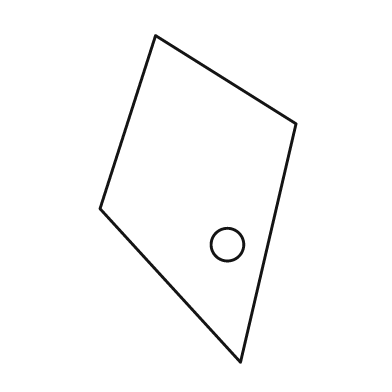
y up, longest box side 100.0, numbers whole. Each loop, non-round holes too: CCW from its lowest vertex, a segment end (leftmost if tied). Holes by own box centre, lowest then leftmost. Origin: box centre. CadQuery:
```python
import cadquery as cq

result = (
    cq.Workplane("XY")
    .moveTo(13.0, -50.0)
    .lineTo(30.0, 23.0)
    .lineTo(-13.0, 50.0)
    .lineTo(-30.0, -3.0)
    .close()
    .moveTo(9.0, -14.0)
    .circle(5.0)
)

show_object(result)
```